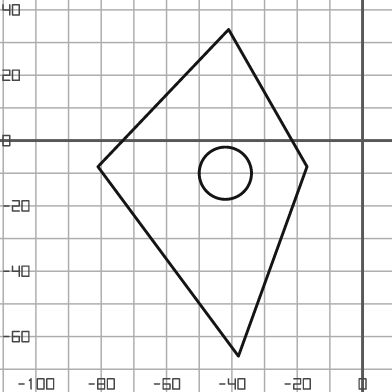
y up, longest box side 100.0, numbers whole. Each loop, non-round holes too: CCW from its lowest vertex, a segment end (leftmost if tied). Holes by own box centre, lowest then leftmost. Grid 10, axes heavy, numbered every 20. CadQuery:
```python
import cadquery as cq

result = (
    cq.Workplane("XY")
    .moveTo(-38.0, -66.0)
    .lineTo(-17.0, -8.0)
    .lineTo(-41.0, 34.0)
    .lineTo(-81.0, -8.0)
    .close()
    .moveTo(-42.0, -10.0)
    .circle(8.0)
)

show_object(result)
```